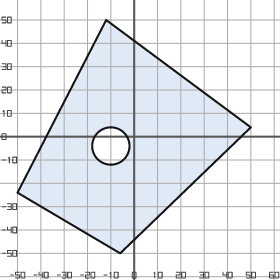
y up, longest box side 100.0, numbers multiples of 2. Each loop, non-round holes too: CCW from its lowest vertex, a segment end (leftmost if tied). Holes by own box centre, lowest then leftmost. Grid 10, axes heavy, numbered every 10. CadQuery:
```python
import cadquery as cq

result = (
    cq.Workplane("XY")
    .moveTo(-6.0, -50.0)
    .lineTo(50.0, 4.0)
    .lineTo(-12.0, 50.0)
    .lineTo(-50.0, -24.0)
    .close()
    .moveTo(-10.0, -4.0)
    .circle(8.0)
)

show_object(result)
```